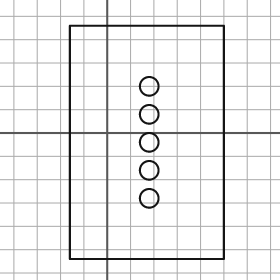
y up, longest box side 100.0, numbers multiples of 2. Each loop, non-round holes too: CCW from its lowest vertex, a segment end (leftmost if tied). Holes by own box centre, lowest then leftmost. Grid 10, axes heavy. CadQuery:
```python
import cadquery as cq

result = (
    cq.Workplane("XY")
    .moveTo(-16.0, -54.0)
    .lineTo(50.0, -54.0)
    .lineTo(50.0, 46.0)
    .lineTo(-16.0, 46.0)
    .close()
    .moveTo(18.0, -28.0)
    .circle(4.0)
    .moveTo(18.0, -16.0)
    .circle(4.0)
    .moveTo(18.0, -4.0)
    .circle(4.0)
    .moveTo(18.0, 8.0)
    .circle(4.0)
    .moveTo(18.0, 20.0)
    .circle(4.0)
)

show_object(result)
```